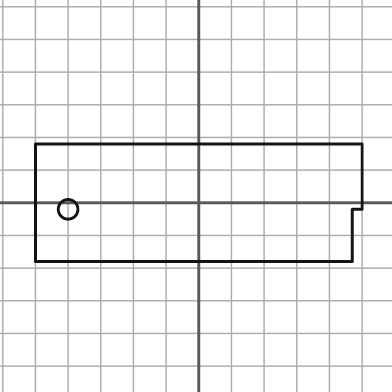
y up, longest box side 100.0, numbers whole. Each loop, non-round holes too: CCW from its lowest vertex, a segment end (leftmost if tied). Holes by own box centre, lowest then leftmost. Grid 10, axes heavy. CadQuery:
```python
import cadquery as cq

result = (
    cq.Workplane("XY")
    .moveTo(-50.0, -18.0)
    .lineTo(47.0, -18.0)
    .lineTo(47.0, -2.0)
    .lineTo(50.0, -2.0)
    .lineTo(50.0, 18.0)
    .lineTo(-50.0, 18.0)
    .close()
    .moveTo(-40.0, -2.0)
    .circle(3.0)
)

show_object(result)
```